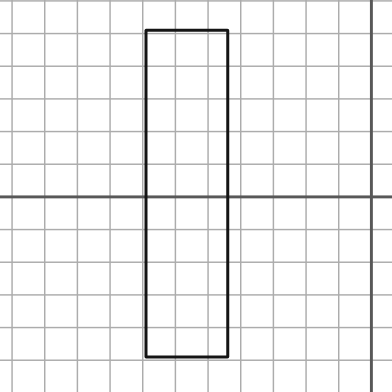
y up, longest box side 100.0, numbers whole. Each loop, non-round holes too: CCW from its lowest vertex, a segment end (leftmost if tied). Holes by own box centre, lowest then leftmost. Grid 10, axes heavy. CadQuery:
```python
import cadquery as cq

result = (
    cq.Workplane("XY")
    .moveTo(-69.0, -49.0)
    .lineTo(-44.0, -49.0)
    .lineTo(-44.0, 51.0)
    .lineTo(-69.0, 51.0)
    .close()
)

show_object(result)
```